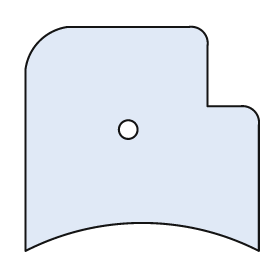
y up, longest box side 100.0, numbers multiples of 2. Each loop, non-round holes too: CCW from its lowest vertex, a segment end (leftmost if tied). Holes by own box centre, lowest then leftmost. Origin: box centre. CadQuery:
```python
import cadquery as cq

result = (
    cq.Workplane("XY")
    .moveTo(-50.0, -48.0)
    .threePointArc((0.0, -36.0), (50.0, -48.0))
    .lineTo(50.0, 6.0)
    .threePointArc((48.0, 12.0), (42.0, 14.0))
    .lineTo(28.0, 14.0)
    .lineTo(28.0, 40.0)
    .threePointArc((26.0, 46.0), (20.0, 48.0))
    .lineTo(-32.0, 48.0)
    .threePointArc((-44.0, 42.0), (-50.0, 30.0))
    .close()
    .moveTo(-6.0, 4.0)
    .circle(4.0)
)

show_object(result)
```